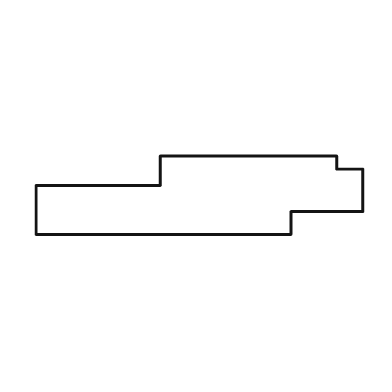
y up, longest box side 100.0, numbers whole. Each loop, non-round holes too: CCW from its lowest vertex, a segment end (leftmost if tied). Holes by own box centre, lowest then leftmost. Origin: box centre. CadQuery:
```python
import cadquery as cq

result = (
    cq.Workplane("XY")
    .moveTo(-50.0, -12.0)
    .lineTo(28.0, -12.0)
    .lineTo(28.0, -5.0)
    .lineTo(50.0, -5.0)
    .lineTo(50.0, 8.0)
    .lineTo(42.0, 8.0)
    .lineTo(42.0, 12.0)
    .lineTo(-12.0, 12.0)
    .lineTo(-12.0, 3.0)
    .lineTo(-50.0, 3.0)
    .close()
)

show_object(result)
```